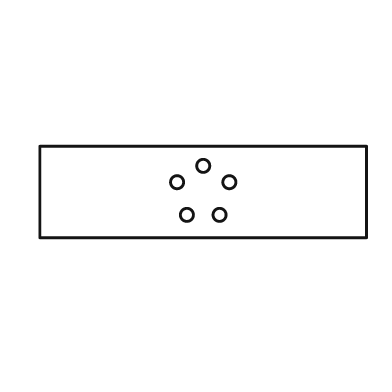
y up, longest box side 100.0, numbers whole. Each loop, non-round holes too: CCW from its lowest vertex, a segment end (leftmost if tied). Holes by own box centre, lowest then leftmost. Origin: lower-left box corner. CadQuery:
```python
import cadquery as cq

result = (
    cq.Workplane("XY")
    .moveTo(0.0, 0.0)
    .lineTo(100.0, 0.0)
    .lineTo(100.0, 28.0)
    .lineTo(0.0, 28.0)
    .close()
    .moveTo(45.0, 7.0)
    .circle(2.0)
    .moveTo(55.0, 7.0)
    .circle(2.0)
    .moveTo(42.0, 17.0)
    .circle(2.0)
    .moveTo(58.0, 17.0)
    .circle(2.0)
    .moveTo(50.0, 22.0)
    .circle(2.0)
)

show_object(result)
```